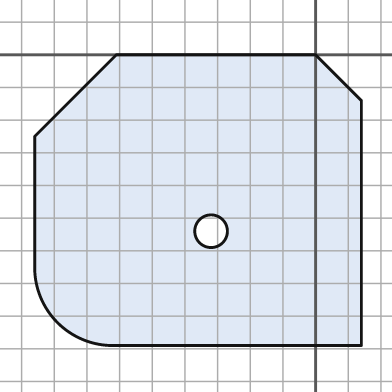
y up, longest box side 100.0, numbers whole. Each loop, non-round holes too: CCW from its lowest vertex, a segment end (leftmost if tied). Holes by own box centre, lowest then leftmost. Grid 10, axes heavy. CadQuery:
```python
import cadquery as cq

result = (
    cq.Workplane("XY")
    .moveTo(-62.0, -89.0)
    .lineTo(14.0, -89.0)
    .lineTo(14.0, -14.0)
    .lineTo(0.0, 0.0)
    .lineTo(-61.0, 0.0)
    .lineTo(-86.0, -25.0)
    .lineTo(-86.0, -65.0)
    .threePointArc((-79.0, -82.0), (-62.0, -89.0))
    .close()
    .moveTo(-32.0, -54.0)
    .circle(5.0)
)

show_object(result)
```